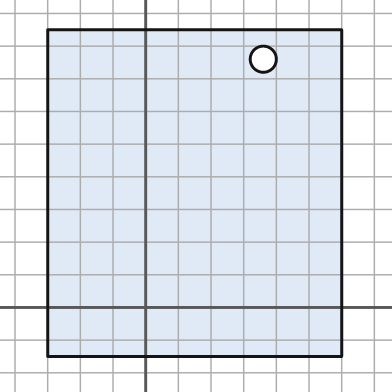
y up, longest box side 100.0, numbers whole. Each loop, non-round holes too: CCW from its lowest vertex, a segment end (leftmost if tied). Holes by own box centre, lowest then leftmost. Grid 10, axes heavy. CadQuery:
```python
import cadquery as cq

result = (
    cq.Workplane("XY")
    .moveTo(-30.0, -15.0)
    .lineTo(60.0, -15.0)
    .lineTo(60.0, 85.0)
    .lineTo(-30.0, 85.0)
    .close()
    .moveTo(36.0, 76.0)
    .circle(4.0)
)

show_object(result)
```